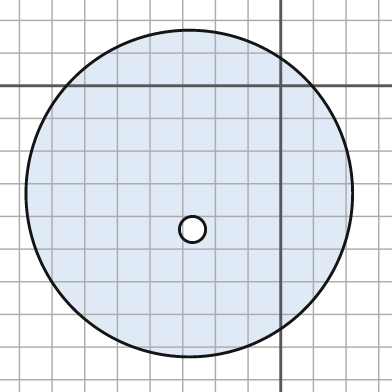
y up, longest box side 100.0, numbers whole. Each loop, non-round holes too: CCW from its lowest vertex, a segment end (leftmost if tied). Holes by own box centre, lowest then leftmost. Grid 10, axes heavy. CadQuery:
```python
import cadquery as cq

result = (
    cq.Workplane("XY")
    .moveTo(-28.0, -33.0)
    .circle(50.0)
    .moveTo(-27.0, -44.0)
    .circle(4.0)
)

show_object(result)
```